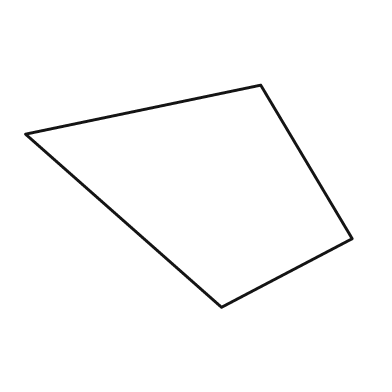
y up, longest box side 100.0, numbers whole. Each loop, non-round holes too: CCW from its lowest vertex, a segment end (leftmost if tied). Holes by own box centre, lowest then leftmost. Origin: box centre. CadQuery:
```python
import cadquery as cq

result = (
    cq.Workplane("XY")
    .moveTo(10.0, -34.0)
    .lineTo(50.0, -13.0)
    .lineTo(22.0, 34.0)
    .lineTo(-50.0, 19.0)
    .close()
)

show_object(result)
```